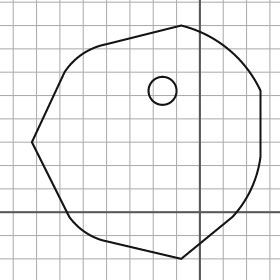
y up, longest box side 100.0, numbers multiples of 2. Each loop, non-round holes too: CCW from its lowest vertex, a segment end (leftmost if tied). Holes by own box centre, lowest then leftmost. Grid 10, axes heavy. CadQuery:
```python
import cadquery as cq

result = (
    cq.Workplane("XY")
    .moveTo(-8.0, -20.0)
    .lineTo(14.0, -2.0)
    .threePointArc((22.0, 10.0), (26.0, 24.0))
    .lineTo(26.0, 52.0)
    .threePointArc((12.0, 70.0), (-8.0, 80.0))
    .lineTo(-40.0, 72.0)
    .threePointArc((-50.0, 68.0), (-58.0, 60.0))
    .lineTo(-72.0, 30.0)
    .lineTo(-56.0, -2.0)
    .threePointArc((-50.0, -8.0), (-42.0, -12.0))
    .close()
    .moveTo(-16.0, 52.0)
    .circle(6.0)
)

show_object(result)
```